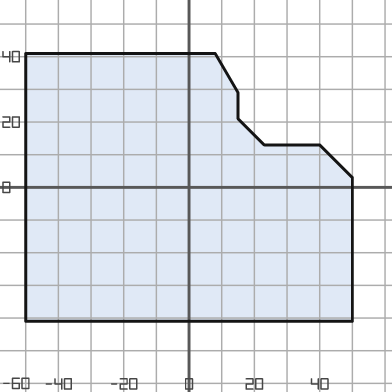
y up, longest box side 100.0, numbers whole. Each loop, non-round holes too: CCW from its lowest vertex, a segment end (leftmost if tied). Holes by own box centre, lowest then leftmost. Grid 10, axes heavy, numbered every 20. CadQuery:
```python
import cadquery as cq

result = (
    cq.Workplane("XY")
    .moveTo(-50.0, -41.0)
    .lineTo(50.0, -41.0)
    .lineTo(50.0, 3.0)
    .lineTo(40.0, 13.0)
    .lineTo(23.0, 13.0)
    .lineTo(15.0, 21.0)
    .lineTo(15.0, 29.0)
    .lineTo(8.0, 41.0)
    .lineTo(-50.0, 41.0)
    .close()
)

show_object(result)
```